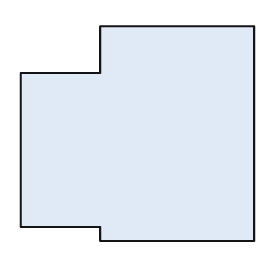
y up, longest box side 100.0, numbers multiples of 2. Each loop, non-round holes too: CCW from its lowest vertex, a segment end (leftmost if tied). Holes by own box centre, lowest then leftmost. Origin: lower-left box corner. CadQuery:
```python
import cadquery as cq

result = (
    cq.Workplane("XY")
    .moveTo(34.0, 0.0)
    .lineTo(100.0, 0.0)
    .lineTo(100.0, 92.0)
    .lineTo(34.0, 92.0)
    .lineTo(34.0, 72.0)
    .lineTo(0.0, 72.0)
    .lineTo(0.0, 6.0)
    .lineTo(34.0, 6.0)
    .close()
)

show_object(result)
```